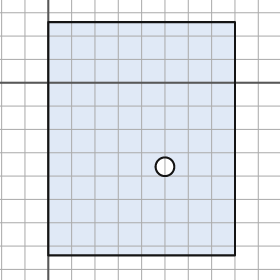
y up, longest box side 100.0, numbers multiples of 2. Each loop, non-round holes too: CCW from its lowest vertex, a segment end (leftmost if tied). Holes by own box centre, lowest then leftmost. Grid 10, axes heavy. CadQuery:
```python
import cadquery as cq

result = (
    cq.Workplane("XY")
    .moveTo(0.0, -74.0)
    .lineTo(80.0, -74.0)
    .lineTo(80.0, 26.0)
    .lineTo(0.0, 26.0)
    .close()
    .moveTo(50.0, -36.0)
    .circle(4.0)
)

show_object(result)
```